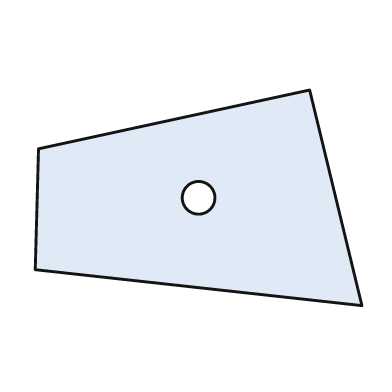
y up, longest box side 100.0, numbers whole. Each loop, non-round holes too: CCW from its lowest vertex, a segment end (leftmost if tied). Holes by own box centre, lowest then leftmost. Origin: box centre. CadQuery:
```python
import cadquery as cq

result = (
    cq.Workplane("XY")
    .moveTo(50.0, -33.0)
    .lineTo(34.0, 33.0)
    .lineTo(-49.0, 15.0)
    .lineTo(-50.0, -22.0)
    .close()
    .moveTo(0.0, 0.0)
    .circle(5.0)
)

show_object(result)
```